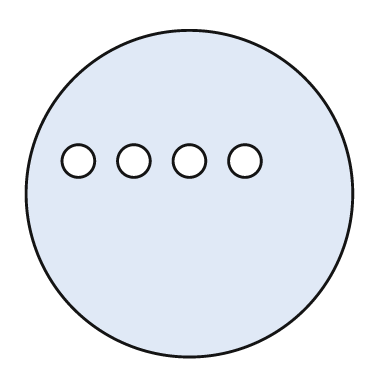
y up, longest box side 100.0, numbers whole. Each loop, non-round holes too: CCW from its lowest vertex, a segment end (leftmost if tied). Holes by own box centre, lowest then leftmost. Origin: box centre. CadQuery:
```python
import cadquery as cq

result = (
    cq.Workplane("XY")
    .moveTo(0.0, 0.0)
    .circle(50.0)
    .moveTo(-34.0, 10.0)
    .circle(5.0)
    .moveTo(-17.0, 10.0)
    .circle(5.0)
    .moveTo(0.0, 10.0)
    .circle(5.0)
    .moveTo(17.0, 10.0)
    .circle(5.0)
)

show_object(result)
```